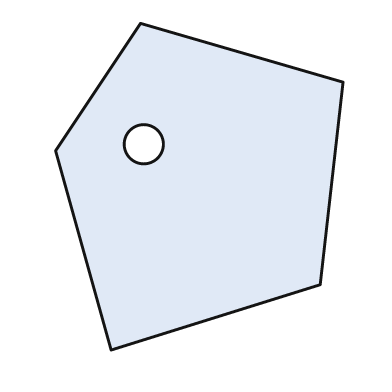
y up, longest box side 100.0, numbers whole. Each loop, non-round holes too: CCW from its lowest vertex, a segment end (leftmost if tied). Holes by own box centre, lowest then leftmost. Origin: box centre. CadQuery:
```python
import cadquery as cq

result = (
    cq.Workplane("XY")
    .moveTo(-27.0, -50.0)
    .lineTo(37.0, -30.0)
    .lineTo(44.0, 32.0)
    .lineTo(-18.0, 50.0)
    .lineTo(-44.0, 11.0)
    .close()
    .moveTo(-17.0, 13.0)
    .circle(6.0)
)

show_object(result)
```